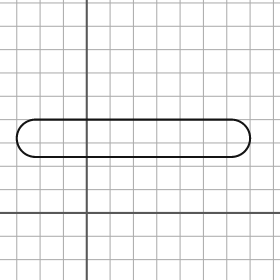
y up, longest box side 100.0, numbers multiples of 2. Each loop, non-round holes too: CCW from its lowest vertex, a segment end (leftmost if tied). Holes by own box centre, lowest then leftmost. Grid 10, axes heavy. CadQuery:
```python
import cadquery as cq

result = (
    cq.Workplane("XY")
    .moveTo(-22.0, 24.0)
    .lineTo(62.0, 24.0)
    .threePointArc((70.0, 32.0), (62.0, 40.0))
    .lineTo(-22.0, 40.0)
    .threePointArc((-30.0, 32.0), (-22.0, 24.0))
    .close()
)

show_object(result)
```